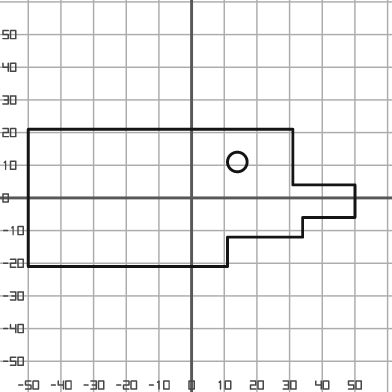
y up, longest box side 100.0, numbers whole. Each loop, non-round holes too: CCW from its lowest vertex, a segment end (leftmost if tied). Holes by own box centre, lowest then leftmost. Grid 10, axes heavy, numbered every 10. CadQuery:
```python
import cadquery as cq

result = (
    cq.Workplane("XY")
    .moveTo(-50.0, -21.0)
    .lineTo(11.0, -21.0)
    .lineTo(11.0, -12.0)
    .lineTo(34.0, -12.0)
    .lineTo(34.0, -6.0)
    .lineTo(50.0, -6.0)
    .lineTo(50.0, 4.0)
    .lineTo(31.0, 4.0)
    .lineTo(31.0, 21.0)
    .lineTo(-50.0, 21.0)
    .close()
    .moveTo(14.0, 11.0)
    .circle(3.0)
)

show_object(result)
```